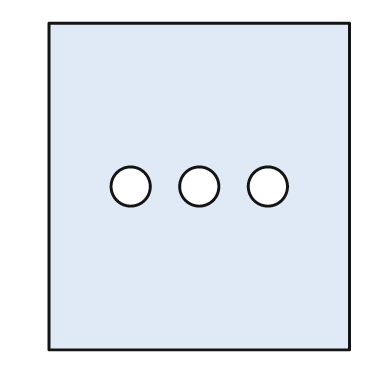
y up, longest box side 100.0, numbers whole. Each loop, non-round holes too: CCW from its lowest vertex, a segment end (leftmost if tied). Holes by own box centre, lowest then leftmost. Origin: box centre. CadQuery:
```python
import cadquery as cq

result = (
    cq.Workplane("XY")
    .moveTo(-46.0, -50.0)
    .lineTo(46.0, -50.0)
    .lineTo(46.0, 50.0)
    .lineTo(-46.0, 50.0)
    .close()
    .moveTo(-21.0, 0.0)
    .circle(6.0)
    .moveTo(0.0, 0.0)
    .circle(6.0)
    .moveTo(21.0, 0.0)
    .circle(6.0)
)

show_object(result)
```